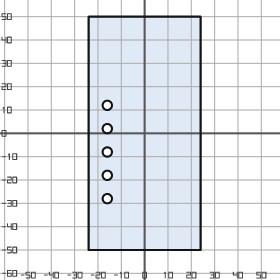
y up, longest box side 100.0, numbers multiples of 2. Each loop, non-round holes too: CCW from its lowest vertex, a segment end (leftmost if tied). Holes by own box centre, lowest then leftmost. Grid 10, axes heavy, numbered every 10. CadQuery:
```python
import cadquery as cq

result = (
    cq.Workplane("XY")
    .moveTo(-24.0, -50.0)
    .lineTo(24.0, -50.0)
    .lineTo(24.0, 50.0)
    .lineTo(-24.0, 50.0)
    .close()
    .moveTo(-16.0, -28.0)
    .circle(2.0)
    .moveTo(-16.0, -18.0)
    .circle(2.0)
    .moveTo(-16.0, -8.0)
    .circle(2.0)
    .moveTo(-16.0, 2.0)
    .circle(2.0)
    .moveTo(-16.0, 12.0)
    .circle(2.0)
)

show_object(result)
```